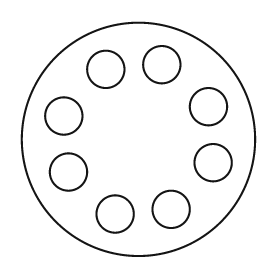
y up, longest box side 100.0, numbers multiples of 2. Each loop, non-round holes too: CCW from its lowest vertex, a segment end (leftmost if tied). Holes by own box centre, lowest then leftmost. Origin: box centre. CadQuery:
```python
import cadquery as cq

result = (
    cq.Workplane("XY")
    .moveTo(0.0, 0.0)
    .circle(50.0)
    .moveTo(-10.0, -32.0)
    .circle(8.0)
    .moveTo(14.0, -30.0)
    .circle(8.0)
    .moveTo(-30.0, -14.0)
    .circle(8.0)
    .moveTo(32.0, -10.0)
    .circle(8.0)
    .moveTo(-32.0, 10.0)
    .circle(8.0)
    .moveTo(30.0, 14.0)
    .circle(8.0)
    .moveTo(-14.0, 30.0)
    .circle(8.0)
    .moveTo(10.0, 32.0)
    .circle(8.0)
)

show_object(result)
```